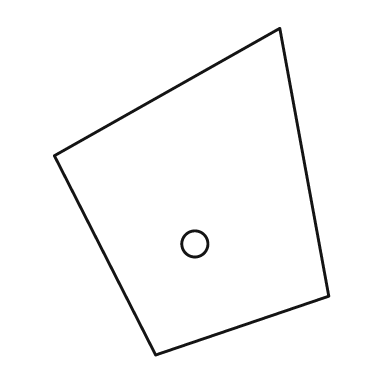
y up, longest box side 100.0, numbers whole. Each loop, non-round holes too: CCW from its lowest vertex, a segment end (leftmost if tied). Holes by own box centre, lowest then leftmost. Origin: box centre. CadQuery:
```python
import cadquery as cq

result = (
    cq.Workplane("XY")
    .moveTo(-11.0, -50.0)
    .lineTo(42.0, -32.0)
    .lineTo(27.0, 50.0)
    .lineTo(-42.0, 11.0)
    .close()
    .moveTo(1.0, -16.0)
    .circle(4.0)
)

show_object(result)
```